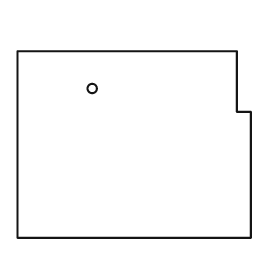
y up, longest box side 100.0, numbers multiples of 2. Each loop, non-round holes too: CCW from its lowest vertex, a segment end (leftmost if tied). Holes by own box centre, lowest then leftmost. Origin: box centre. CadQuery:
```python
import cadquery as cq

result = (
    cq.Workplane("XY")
    .moveTo(-50.0, -40.0)
    .lineTo(50.0, -40.0)
    .lineTo(50.0, 14.0)
    .lineTo(44.0, 14.0)
    .lineTo(44.0, 40.0)
    .lineTo(-50.0, 40.0)
    .close()
    .moveTo(-18.0, 24.0)
    .circle(2.0)
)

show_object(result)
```